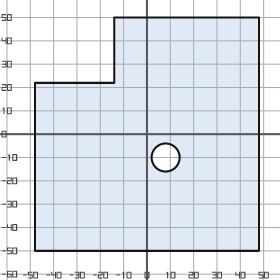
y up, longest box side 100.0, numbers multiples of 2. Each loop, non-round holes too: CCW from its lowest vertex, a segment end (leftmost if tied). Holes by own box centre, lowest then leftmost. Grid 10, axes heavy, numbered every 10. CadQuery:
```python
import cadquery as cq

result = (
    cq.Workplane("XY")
    .moveTo(-48.0, -50.0)
    .lineTo(48.0, -50.0)
    .lineTo(48.0, 50.0)
    .lineTo(-14.0, 50.0)
    .lineTo(-14.0, 22.0)
    .lineTo(-48.0, 22.0)
    .close()
    .moveTo(8.0, -10.0)
    .circle(6.0)
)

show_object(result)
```